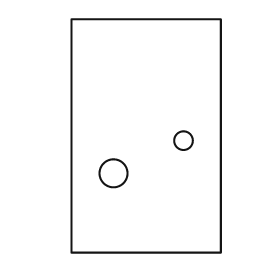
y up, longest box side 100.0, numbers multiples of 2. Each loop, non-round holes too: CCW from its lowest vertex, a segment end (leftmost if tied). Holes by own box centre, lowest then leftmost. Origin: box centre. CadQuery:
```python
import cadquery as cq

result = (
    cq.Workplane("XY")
    .moveTo(-32.0, -50.0)
    .lineTo(32.0, -50.0)
    .lineTo(32.0, 50.0)
    .lineTo(-32.0, 50.0)
    .close()
    .moveTo(-14.0, -16.0)
    .circle(6.0)
    .moveTo(16.0, -2.0)
    .circle(4.0)
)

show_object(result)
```